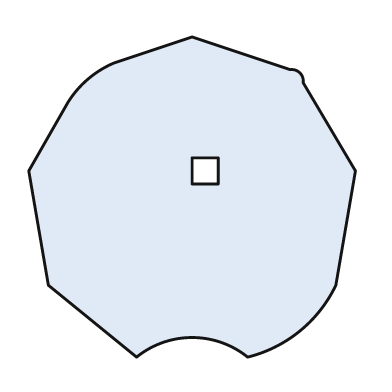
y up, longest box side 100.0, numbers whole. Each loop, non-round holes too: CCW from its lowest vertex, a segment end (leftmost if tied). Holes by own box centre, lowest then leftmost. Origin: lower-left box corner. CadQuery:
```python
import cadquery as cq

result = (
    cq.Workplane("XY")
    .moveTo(33.0, 0.0)
    .threePointArc((50.0, 6.0), (67.0, 0.0))
    .threePointArc((83.0, 8.0), (94.0, 22.0))
    .lineTo(100.0, 57.0)
    .lineTo(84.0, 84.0)
    .threePointArc((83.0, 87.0), (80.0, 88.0))
    .lineTo(50.0, 98.0)
    .lineTo(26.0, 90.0)
    .threePointArc((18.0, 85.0), (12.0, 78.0))
    .lineTo(0.0, 57.0)
    .lineTo(6.0, 22.0)
    .close()
    .moveTo(50.0, 53.0)
    .lineTo(58.0, 53.0)
    .lineTo(58.0, 61.0)
    .lineTo(50.0, 61.0)
    .close()
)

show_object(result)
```